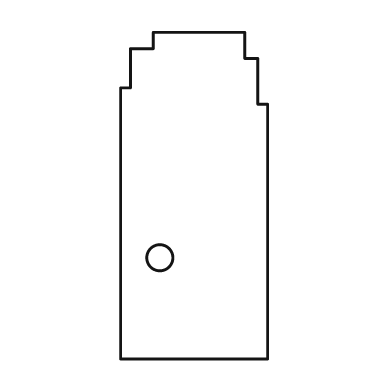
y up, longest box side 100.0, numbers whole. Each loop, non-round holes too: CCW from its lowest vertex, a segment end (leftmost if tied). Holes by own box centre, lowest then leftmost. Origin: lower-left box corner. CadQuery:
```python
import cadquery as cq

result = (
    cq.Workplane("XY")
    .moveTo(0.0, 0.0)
    .lineTo(45.0, 0.0)
    .lineTo(45.0, 78.0)
    .lineTo(42.0, 78.0)
    .lineTo(42.0, 92.0)
    .lineTo(38.0, 92.0)
    .lineTo(38.0, 100.0)
    .lineTo(10.0, 100.0)
    .lineTo(10.0, 95.0)
    .lineTo(3.0, 95.0)
    .lineTo(3.0, 83.0)
    .lineTo(0.0, 83.0)
    .close()
    .moveTo(12.0, 31.0)
    .circle(4.0)
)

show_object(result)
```